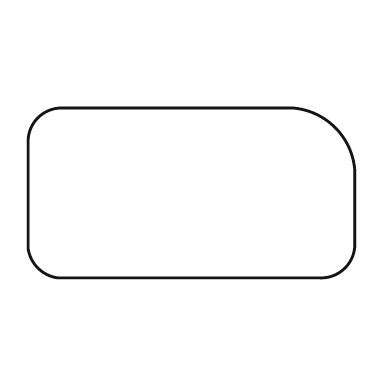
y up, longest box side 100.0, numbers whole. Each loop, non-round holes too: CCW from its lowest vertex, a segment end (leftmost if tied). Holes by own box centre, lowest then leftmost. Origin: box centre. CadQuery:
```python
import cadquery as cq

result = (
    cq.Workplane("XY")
    .moveTo(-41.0, -26.0)
    .lineTo(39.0, -26.0)
    .threePointArc((47.0, -23.0), (50.0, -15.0))
    .lineTo(50.0, 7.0)
    .threePointArc((44.0, 20.0), (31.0, 26.0))
    .lineTo(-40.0, 26.0)
    .threePointArc((-47.0, 23.0), (-50.0, 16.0))
    .lineTo(-50.0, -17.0)
    .threePointArc((-47.0, -23.0), (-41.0, -26.0))
    .close()
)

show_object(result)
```